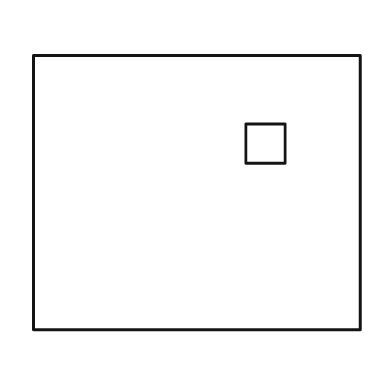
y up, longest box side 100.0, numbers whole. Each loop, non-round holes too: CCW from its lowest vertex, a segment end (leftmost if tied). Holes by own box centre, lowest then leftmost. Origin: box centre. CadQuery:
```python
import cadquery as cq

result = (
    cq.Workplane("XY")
    .moveTo(-50.0, -42.0)
    .lineTo(50.0, -42.0)
    .lineTo(50.0, 42.0)
    .lineTo(-50.0, 42.0)
    .close()
    .moveTo(15.0, 9.0)
    .lineTo(27.0, 9.0)
    .lineTo(27.0, 21.0)
    .lineTo(15.0, 21.0)
    .close()
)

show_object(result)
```